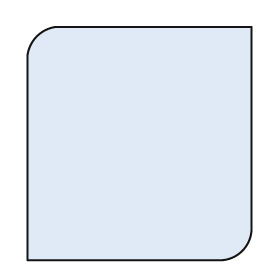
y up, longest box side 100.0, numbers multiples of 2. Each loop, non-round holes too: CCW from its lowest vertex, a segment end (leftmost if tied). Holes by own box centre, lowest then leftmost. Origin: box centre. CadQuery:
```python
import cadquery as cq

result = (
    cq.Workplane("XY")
    .moveTo(-48.0, -50.0)
    .lineTo(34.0, -50.0)
    .threePointArc((44.0, -46.0), (48.0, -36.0))
    .lineTo(48.0, 50.0)
    .lineTo(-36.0, 50.0)
    .threePointArc((-44.0, 46.0), (-48.0, 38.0))
    .close()
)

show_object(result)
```